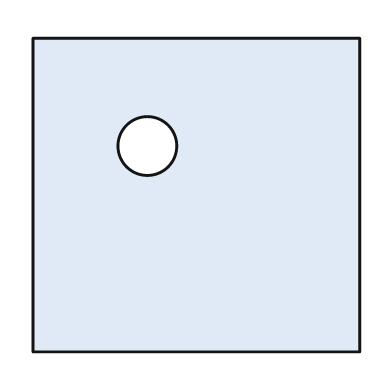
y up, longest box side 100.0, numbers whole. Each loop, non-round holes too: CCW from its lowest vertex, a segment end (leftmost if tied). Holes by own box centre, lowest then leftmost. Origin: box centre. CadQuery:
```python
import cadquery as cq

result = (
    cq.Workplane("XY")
    .moveTo(-50.0, -48.0)
    .lineTo(50.0, -48.0)
    .lineTo(50.0, 48.0)
    .lineTo(-50.0, 48.0)
    .close()
    .moveTo(-15.0, 15.0)
    .circle(9.0)
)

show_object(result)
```